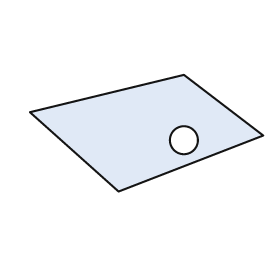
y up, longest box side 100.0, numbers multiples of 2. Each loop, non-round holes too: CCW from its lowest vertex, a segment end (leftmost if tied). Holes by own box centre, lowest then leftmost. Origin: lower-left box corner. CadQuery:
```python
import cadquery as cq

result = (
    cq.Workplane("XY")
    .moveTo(38.0, 0.0)
    .lineTo(100.0, 24.0)
    .lineTo(66.0, 50.0)
    .lineTo(0.0, 34.0)
    .close()
    .moveTo(66.0, 22.0)
    .circle(6.0)
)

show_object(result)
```